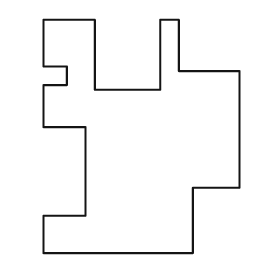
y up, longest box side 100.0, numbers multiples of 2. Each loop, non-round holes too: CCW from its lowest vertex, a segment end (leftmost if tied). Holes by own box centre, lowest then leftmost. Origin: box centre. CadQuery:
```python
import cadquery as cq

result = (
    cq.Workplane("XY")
    .moveTo(-42.0, -50.0)
    .lineTo(22.0, -50.0)
    .lineTo(22.0, -22.0)
    .lineTo(42.0, -22.0)
    .lineTo(42.0, 28.0)
    .lineTo(16.0, 28.0)
    .lineTo(16.0, 50.0)
    .lineTo(8.0, 50.0)
    .lineTo(8.0, 20.0)
    .lineTo(-20.0, 20.0)
    .lineTo(-20.0, 50.0)
    .lineTo(-42.0, 50.0)
    .lineTo(-42.0, 30.0)
    .lineTo(-32.0, 30.0)
    .lineTo(-32.0, 22.0)
    .lineTo(-42.0, 22.0)
    .lineTo(-42.0, 4.0)
    .lineTo(-24.0, 4.0)
    .lineTo(-24.0, -34.0)
    .lineTo(-42.0, -34.0)
    .close()
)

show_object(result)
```